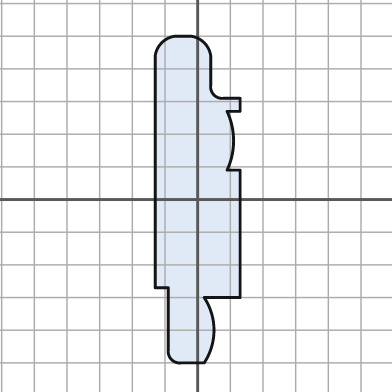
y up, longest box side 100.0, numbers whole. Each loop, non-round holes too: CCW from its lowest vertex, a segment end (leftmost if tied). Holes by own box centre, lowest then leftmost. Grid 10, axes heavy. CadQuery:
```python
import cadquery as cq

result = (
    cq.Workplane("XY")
    .moveTo(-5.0, -50.0)
    .lineTo(2.0, -50.0)
    .threePointArc((5.0, -40.0), (2.0, -30.0))
    .lineTo(13.0, -30.0)
    .lineTo(13.0, 9.0)
    .lineTo(9.0, 9.0)
    .threePointArc((11.0, 18.0), (9.0, 27.0))
    .lineTo(13.0, 27.0)
    .lineTo(13.0, 31.0)
    .lineTo(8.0, 31.0)
    .threePointArc((5.0, 32.0), (4.0, 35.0))
    .lineTo(4.0, 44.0)
    .threePointArc((2.0, 48.0), (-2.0, 50.0))
    .lineTo(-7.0, 50.0)
    .threePointArc((-11.0, 48.0), (-13.0, 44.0))
    .lineTo(-13.0, -27.0)
    .lineTo(-9.0, -27.0)
    .lineTo(-9.0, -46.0)
    .threePointArc((-8.0, -49.0), (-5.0, -50.0))
    .close()
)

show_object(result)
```